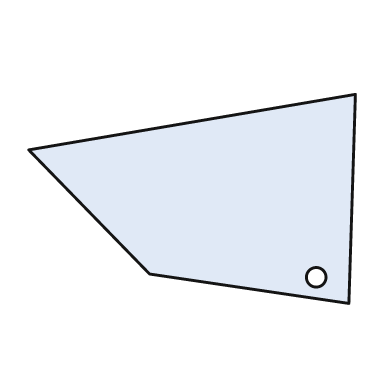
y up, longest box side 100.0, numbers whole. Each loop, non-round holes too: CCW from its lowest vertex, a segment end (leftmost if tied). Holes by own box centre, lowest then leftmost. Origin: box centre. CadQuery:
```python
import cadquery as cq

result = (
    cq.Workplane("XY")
    .moveTo(48.0, -32.0)
    .lineTo(50.0, 32.0)
    .lineTo(-50.0, 15.0)
    .lineTo(-13.0, -23.0)
    .close()
    .moveTo(38.0, -24.0)
    .circle(3.0)
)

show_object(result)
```